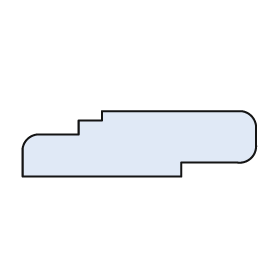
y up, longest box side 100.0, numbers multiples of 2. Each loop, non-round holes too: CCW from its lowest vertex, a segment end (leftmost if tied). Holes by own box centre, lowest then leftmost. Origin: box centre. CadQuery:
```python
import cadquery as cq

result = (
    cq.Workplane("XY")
    .moveTo(-50.0, -14.0)
    .lineTo(18.0, -14.0)
    .lineTo(18.0, -8.0)
    .lineTo(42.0, -8.0)
    .threePointArc((48.0, -6.0), (50.0, 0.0))
    .lineTo(50.0, 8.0)
    .threePointArc((48.0, 12.0), (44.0, 14.0))
    .lineTo(-16.0, 14.0)
    .lineTo(-16.0, 10.0)
    .lineTo(-26.0, 10.0)
    .lineTo(-26.0, 4.0)
    .lineTo(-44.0, 4.0)
    .threePointArc((-48.0, 2.0), (-50.0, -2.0))
    .close()
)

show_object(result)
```